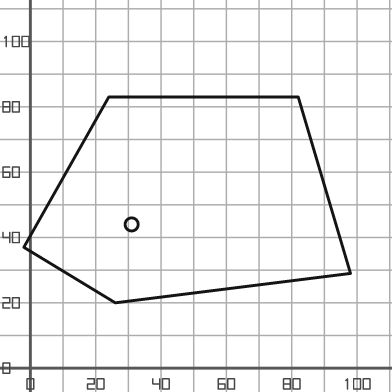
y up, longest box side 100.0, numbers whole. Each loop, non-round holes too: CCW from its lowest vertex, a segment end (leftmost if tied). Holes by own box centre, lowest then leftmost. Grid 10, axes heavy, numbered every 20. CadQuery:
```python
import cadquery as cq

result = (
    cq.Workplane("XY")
    .moveTo(26.0, 20.0)
    .lineTo(98.0, 29.0)
    .lineTo(82.0, 83.0)
    .lineTo(24.0, 83.0)
    .lineTo(-2.0, 37.0)
    .close()
    .moveTo(31.0, 44.0)
    .circle(2.0)
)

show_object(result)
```